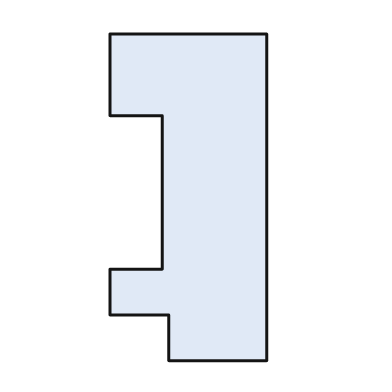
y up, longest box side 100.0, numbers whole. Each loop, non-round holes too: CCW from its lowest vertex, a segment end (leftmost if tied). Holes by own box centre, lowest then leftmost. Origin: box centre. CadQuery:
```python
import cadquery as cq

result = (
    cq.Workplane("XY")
    .moveTo(-6.0, -50.0)
    .lineTo(24.0, -50.0)
    .lineTo(24.0, 50.0)
    .lineTo(-24.0, 50.0)
    .lineTo(-24.0, 25.0)
    .lineTo(-8.0, 25.0)
    .lineTo(-8.0, -22.0)
    .lineTo(-24.0, -22.0)
    .lineTo(-24.0, -36.0)
    .lineTo(-6.0, -36.0)
    .close()
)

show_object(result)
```